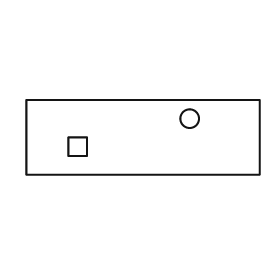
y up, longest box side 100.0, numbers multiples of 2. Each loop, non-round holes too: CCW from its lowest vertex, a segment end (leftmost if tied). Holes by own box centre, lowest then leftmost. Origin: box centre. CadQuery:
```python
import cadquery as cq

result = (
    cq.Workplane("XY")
    .moveTo(-50.0, -16.0)
    .lineTo(50.0, -16.0)
    .lineTo(50.0, 16.0)
    .lineTo(-50.0, 16.0)
    .close()
    .moveTo(-32.0, -8.0)
    .lineTo(-24.0, -8.0)
    .lineTo(-24.0, 0.0)
    .lineTo(-32.0, 0.0)
    .close()
    .moveTo(20.0, 8.0)
    .circle(4.0)
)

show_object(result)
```